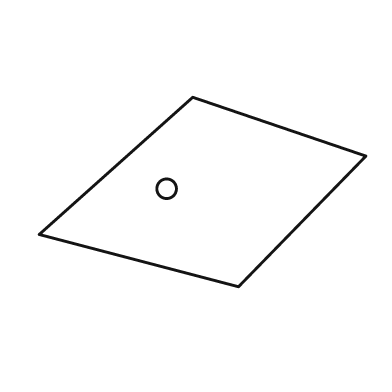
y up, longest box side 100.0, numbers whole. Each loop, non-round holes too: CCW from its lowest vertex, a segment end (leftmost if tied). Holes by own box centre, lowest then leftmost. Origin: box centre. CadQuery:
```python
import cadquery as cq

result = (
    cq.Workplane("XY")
    .moveTo(11.0, -29.0)
    .lineTo(50.0, 11.0)
    .lineTo(-3.0, 29.0)
    .lineTo(-50.0, -13.0)
    .close()
    .moveTo(-11.0, 1.0)
    .circle(3.0)
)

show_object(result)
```